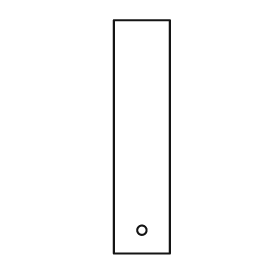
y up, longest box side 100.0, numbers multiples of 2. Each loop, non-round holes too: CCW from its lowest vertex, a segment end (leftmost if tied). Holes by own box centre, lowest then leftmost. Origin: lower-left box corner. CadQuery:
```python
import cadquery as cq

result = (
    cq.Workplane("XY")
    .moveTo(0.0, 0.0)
    .lineTo(24.0, 0.0)
    .lineTo(24.0, 100.0)
    .lineTo(0.0, 100.0)
    .close()
    .moveTo(12.0, 10.0)
    .circle(2.0)
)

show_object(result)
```